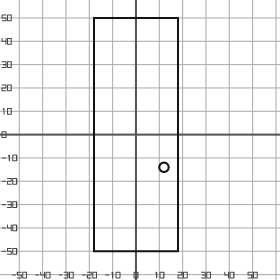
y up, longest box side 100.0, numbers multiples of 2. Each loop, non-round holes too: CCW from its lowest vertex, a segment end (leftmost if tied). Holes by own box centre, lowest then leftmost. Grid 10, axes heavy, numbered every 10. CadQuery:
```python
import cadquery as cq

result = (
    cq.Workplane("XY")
    .moveTo(-18.0, -50.0)
    .lineTo(18.0, -50.0)
    .lineTo(18.0, 50.0)
    .lineTo(-18.0, 50.0)
    .close()
    .moveTo(12.0, -14.0)
    .circle(2.0)
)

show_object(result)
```